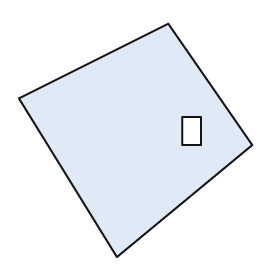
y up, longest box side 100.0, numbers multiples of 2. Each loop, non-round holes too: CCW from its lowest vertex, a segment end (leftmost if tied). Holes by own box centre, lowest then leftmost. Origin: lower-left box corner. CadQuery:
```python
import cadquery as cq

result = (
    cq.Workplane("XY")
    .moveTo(42.0, 0.0)
    .lineTo(100.0, 48.0)
    .lineTo(64.0, 100.0)
    .lineTo(0.0, 68.0)
    .close()
    .moveTo(70.0, 48.0)
    .lineTo(78.0, 48.0)
    .lineTo(78.0, 60.0)
    .lineTo(70.0, 60.0)
    .close()
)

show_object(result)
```